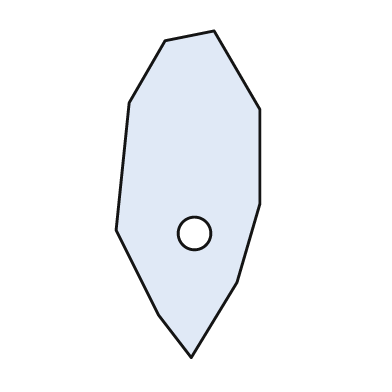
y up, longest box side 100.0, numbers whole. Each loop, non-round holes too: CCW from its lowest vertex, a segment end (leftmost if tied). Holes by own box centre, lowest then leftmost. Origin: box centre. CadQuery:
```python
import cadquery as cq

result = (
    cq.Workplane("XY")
    .moveTo(1.0, -50.0)
    .lineTo(15.0, -27.0)
    .lineTo(22.0, -3.0)
    .lineTo(22.0, 26.0)
    .lineTo(8.0, 50.0)
    .lineTo(-7.0, 47.0)
    .lineTo(-18.0, 28.0)
    .lineTo(-22.0, -11.0)
    .lineTo(-9.0, -37.0)
    .close()
    .moveTo(2.0, -12.0)
    .circle(5.0)
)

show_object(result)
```